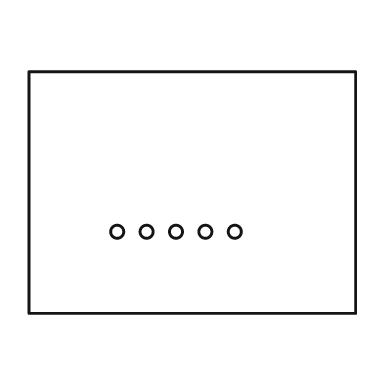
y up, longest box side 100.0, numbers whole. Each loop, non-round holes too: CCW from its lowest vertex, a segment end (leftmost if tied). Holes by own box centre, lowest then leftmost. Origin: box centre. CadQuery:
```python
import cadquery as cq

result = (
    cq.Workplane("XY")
    .moveTo(-50.0, -37.0)
    .lineTo(50.0, -37.0)
    .lineTo(50.0, 37.0)
    .lineTo(-50.0, 37.0)
    .close()
    .moveTo(-23.0, -12.0)
    .circle(2.0)
    .moveTo(-14.0, -12.0)
    .circle(2.0)
    .moveTo(-5.0, -12.0)
    .circle(2.0)
    .moveTo(4.0, -12.0)
    .circle(2.0)
    .moveTo(13.0, -12.0)
    .circle(2.0)
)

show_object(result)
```